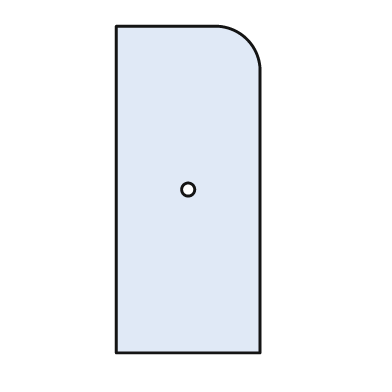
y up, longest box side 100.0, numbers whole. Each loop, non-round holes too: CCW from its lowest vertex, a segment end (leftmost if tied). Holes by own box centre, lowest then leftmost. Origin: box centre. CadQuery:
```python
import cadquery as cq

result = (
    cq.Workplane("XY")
    .moveTo(-22.0, -50.0)
    .lineTo(22.0, -50.0)
    .lineTo(22.0, 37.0)
    .threePointArc((18.0, 46.0), (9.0, 50.0))
    .lineTo(-22.0, 50.0)
    .close()
    .moveTo(0.0, 0.0)
    .circle(2.0)
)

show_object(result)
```